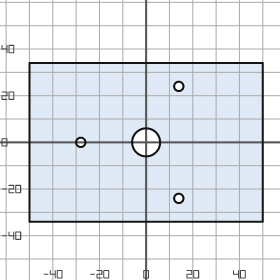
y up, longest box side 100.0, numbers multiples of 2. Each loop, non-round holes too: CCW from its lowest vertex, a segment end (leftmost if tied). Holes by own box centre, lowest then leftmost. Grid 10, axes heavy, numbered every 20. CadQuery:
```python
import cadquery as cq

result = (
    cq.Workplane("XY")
    .moveTo(-50.0, -34.0)
    .lineTo(50.0, -34.0)
    .lineTo(50.0, 34.0)
    .lineTo(-50.0, 34.0)
    .close()
    .moveTo(14.0, -24.0)
    .circle(2.0)
    .moveTo(-28.0, 0.0)
    .circle(2.0)
    .moveTo(0.0, 0.0)
    .circle(6.0)
    .moveTo(14.0, 24.0)
    .circle(2.0)
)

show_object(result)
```